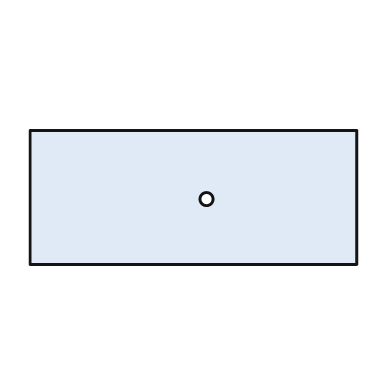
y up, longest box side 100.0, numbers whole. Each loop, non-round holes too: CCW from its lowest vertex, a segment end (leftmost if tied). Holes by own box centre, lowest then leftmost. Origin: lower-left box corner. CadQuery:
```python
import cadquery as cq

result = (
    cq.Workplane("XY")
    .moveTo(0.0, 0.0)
    .lineTo(100.0, 0.0)
    .lineTo(100.0, 41.0)
    .lineTo(0.0, 41.0)
    .close()
    .moveTo(54.0, 20.0)
    .circle(2.0)
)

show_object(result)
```